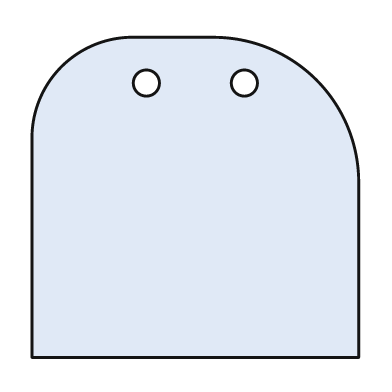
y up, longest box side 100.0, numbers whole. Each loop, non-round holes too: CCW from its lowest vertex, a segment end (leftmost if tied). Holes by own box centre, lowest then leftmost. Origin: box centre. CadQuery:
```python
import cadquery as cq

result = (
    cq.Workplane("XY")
    .moveTo(-50.0, -49.0)
    .lineTo(50.0, -49.0)
    .lineTo(50.0, 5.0)
    .threePointArc((37.0, 36.0), (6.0, 49.0))
    .lineTo(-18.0, 49.0)
    .threePointArc((-41.0, 40.0), (-50.0, 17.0))
    .close()
    .moveTo(-15.0, 35.0)
    .circle(4.0)
    .moveTo(15.0, 35.0)
    .circle(4.0)
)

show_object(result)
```